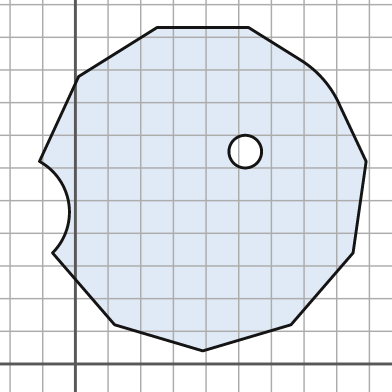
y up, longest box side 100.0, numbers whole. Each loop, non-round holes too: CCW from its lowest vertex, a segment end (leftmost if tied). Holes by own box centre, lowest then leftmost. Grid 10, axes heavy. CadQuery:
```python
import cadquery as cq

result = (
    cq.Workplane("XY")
    .moveTo(39.0, 4.0)
    .lineTo(66.0, 12.0)
    .lineTo(85.0, 34.0)
    .lineTo(89.0, 62.0)
    .lineTo(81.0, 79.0)
    .threePointArc((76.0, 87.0), (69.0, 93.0))
    .lineTo(53.0, 103.0)
    .lineTo(25.0, 103.0)
    .lineTo(1.0, 88.0)
    .lineTo(-11.0, 62.0)
    .threePointArc((-2.0, 49.0), (-7.0, 34.0))
    .lineTo(12.0, 12.0)
    .close()
    .moveTo(52.0, 65.0)
    .circle(5.0)
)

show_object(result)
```